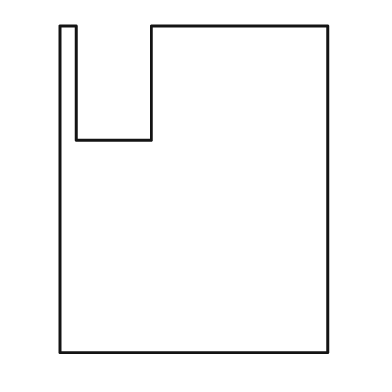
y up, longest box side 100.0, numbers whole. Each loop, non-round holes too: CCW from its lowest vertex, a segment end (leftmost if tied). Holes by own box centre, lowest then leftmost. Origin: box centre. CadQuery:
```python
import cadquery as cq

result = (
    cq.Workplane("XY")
    .moveTo(-41.0, -50.0)
    .lineTo(41.0, -50.0)
    .lineTo(41.0, 50.0)
    .lineTo(-13.0, 50.0)
    .lineTo(-13.0, 15.0)
    .lineTo(-36.0, 15.0)
    .lineTo(-36.0, 50.0)
    .lineTo(-41.0, 50.0)
    .close()
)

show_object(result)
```